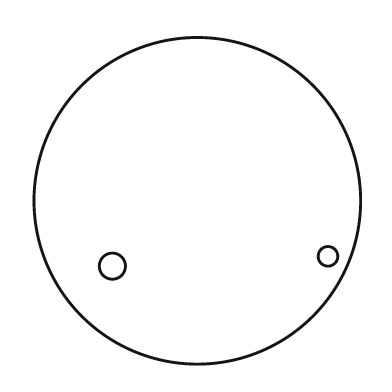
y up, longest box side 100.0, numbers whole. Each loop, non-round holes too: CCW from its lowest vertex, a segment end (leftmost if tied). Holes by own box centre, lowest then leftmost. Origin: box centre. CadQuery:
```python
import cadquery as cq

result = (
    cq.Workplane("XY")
    .moveTo(0.0, 0.0)
    .circle(50.0)
    .moveTo(-26.0, -20.0)
    .circle(4.0)
    .moveTo(40.0, -17.0)
    .circle(3.0)
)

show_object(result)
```